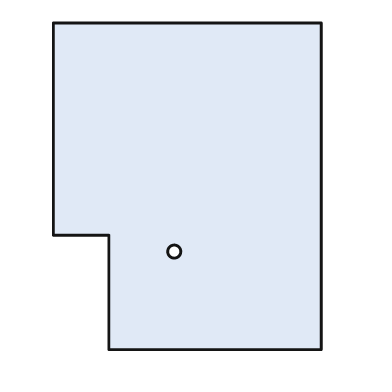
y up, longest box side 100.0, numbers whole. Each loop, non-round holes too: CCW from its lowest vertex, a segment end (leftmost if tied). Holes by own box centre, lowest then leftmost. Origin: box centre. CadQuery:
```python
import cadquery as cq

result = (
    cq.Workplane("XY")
    .moveTo(-24.0, -50.0)
    .lineTo(41.0, -50.0)
    .lineTo(41.0, 50.0)
    .lineTo(-41.0, 50.0)
    .lineTo(-41.0, -15.0)
    .lineTo(-24.0, -15.0)
    .close()
    .moveTo(-4.0, -20.0)
    .circle(2.0)
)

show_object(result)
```